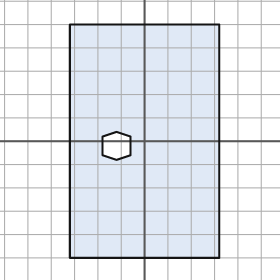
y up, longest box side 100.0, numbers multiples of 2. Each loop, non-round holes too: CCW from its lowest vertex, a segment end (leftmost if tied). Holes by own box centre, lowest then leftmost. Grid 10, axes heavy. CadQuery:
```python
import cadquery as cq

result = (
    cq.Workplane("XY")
    .moveTo(-32.0, -50.0)
    .lineTo(32.0, -50.0)
    .lineTo(32.0, 50.0)
    .lineTo(-32.0, 50.0)
    .close()
    .moveTo(-12.0, -8.0)
    .lineTo(-6.0, -6.0)
    .lineTo(-6.0, 2.0)
    .lineTo(-12.0, 4.0)
    .lineTo(-18.0, 2.0)
    .lineTo(-18.0, -6.0)
    .close()
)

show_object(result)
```